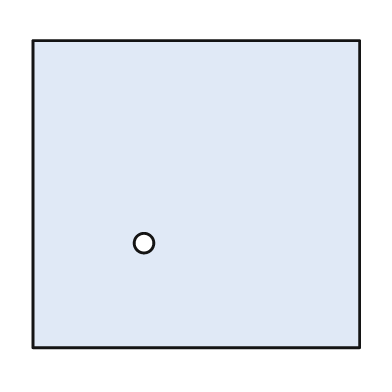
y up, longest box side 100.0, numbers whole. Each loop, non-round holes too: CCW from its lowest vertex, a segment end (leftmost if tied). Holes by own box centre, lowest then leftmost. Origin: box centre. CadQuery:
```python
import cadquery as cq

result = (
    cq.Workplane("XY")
    .moveTo(-50.0, -47.0)
    .lineTo(50.0, -47.0)
    .lineTo(50.0, 47.0)
    .lineTo(-50.0, 47.0)
    .close()
    .moveTo(-16.0, -15.0)
    .circle(3.0)
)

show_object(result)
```